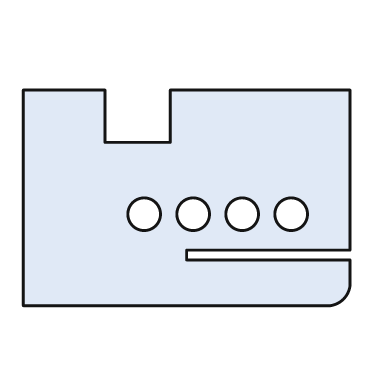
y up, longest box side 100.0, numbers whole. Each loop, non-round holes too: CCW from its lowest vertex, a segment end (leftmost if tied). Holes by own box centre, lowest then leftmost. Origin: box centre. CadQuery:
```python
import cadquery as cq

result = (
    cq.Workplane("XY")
    .moveTo(-50.0, -33.0)
    .lineTo(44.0, -33.0)
    .threePointArc((48.0, -31.0), (50.0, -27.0))
    .lineTo(50.0, -19.0)
    .lineTo(0.0, -19.0)
    .lineTo(0.0, -16.0)
    .lineTo(50.0, -16.0)
    .lineTo(50.0, 33.0)
    .lineTo(-5.0, 33.0)
    .lineTo(-5.0, 17.0)
    .lineTo(-25.0, 17.0)
    .lineTo(-25.0, 33.0)
    .lineTo(-50.0, 33.0)
    .close()
    .moveTo(-13.0, -5.0)
    .circle(5.0)
    .moveTo(2.0, -5.0)
    .circle(5.0)
    .moveTo(17.0, -5.0)
    .circle(5.0)
    .moveTo(32.0, -5.0)
    .circle(5.0)
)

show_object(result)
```